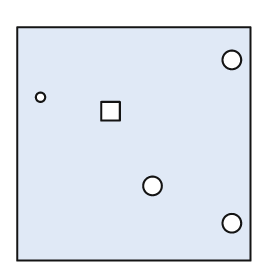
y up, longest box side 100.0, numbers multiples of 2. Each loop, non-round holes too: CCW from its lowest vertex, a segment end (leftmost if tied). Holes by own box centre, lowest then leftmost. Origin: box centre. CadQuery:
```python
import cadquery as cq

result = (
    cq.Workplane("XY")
    .moveTo(-50.0, -50.0)
    .lineTo(50.0, -50.0)
    .lineTo(50.0, 50.0)
    .lineTo(-50.0, 50.0)
    .close()
    .moveTo(42.0, -34.0)
    .circle(4.0)
    .moveTo(8.0, -18.0)
    .circle(4.0)
    .moveTo(-14.0, 10.0)
    .lineTo(-6.0, 10.0)
    .lineTo(-6.0, 18.0)
    .lineTo(-14.0, 18.0)
    .close()
    .moveTo(-40.0, 20.0)
    .circle(2.0)
    .moveTo(42.0, 36.0)
    .circle(4.0)
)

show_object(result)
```